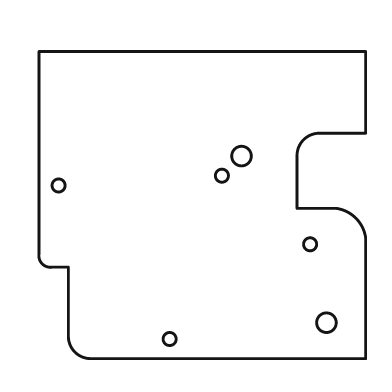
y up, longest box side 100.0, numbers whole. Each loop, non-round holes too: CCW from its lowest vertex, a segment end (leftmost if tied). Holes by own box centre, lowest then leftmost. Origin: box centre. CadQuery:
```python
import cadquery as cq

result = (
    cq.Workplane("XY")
    .moveTo(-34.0, -47.0)
    .lineTo(50.0, -47.0)
    .lineTo(50.0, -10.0)
    .threePointArc((47.0, -4.0), (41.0, -1.0))
    .lineTo(29.0, -1.0)
    .lineTo(29.0, 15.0)
    .threePointArc((31.0, 20.0), (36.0, 22.0))
    .lineTo(50.0, 22.0)
    .lineTo(50.0, 47.0)
    .lineTo(-50.0, 47.0)
    .lineTo(-50.0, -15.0)
    .threePointArc((-49.0, -18.0), (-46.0, -19.0))
    .lineTo(-41.0, -19.0)
    .lineTo(-41.0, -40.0)
    .threePointArc((-39.0, -45.0), (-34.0, -47.0))
    .close()
    .moveTo(-10.0, -41.0)
    .circle(2.0)
    .moveTo(38.0, -36.0)
    .circle(3.0)
    .moveTo(33.0, -12.0)
    .circle(2.0)
    .moveTo(-44.0, 6.0)
    .circle(2.0)
    .moveTo(6.0, 9.0)
    .circle(2.0)
    .moveTo(12.0, 15.0)
    .circle(3.0)
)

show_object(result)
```